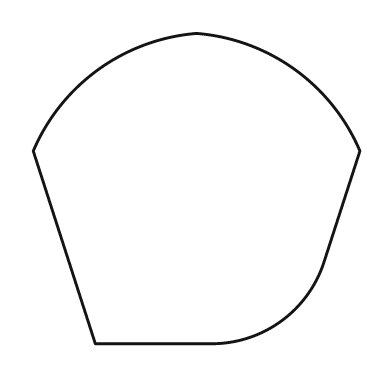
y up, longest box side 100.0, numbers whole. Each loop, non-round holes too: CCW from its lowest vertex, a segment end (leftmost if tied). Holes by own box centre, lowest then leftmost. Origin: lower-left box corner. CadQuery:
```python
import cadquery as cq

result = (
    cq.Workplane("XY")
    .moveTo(19.0, 0.0)
    .lineTo(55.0, 0.0)
    .threePointArc((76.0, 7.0), (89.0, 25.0))
    .lineTo(100.0, 59.0)
    .threePointArc((80.0, 84.0), (50.0, 95.0))
    .threePointArc((20.0, 84.0), (0.0, 59.0))
    .close()
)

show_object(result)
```